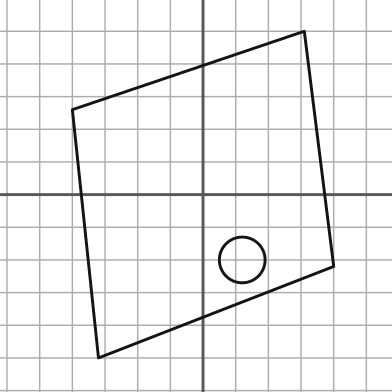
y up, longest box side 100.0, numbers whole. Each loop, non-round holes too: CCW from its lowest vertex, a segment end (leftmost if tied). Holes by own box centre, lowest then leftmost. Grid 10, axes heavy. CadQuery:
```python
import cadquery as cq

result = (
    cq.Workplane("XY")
    .moveTo(-32.0, -50.0)
    .lineTo(40.0, -22.0)
    .lineTo(31.0, 50.0)
    .lineTo(-40.0, 26.0)
    .close()
    .moveTo(12.0, -20.0)
    .circle(7.0)
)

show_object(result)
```